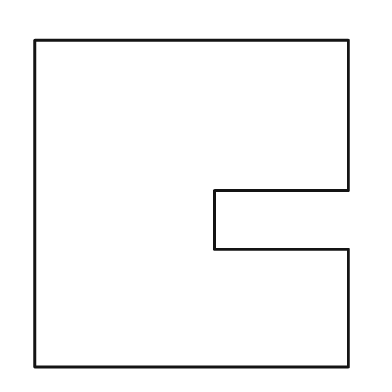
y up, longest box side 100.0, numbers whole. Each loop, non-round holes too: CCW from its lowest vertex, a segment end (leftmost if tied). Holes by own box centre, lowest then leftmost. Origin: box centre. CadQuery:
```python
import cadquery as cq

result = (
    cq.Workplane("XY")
    .moveTo(-48.0, -50.0)
    .lineTo(48.0, -50.0)
    .lineTo(48.0, -14.0)
    .lineTo(7.0, -14.0)
    .lineTo(7.0, 4.0)
    .lineTo(48.0, 4.0)
    .lineTo(48.0, 50.0)
    .lineTo(-48.0, 50.0)
    .close()
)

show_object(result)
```